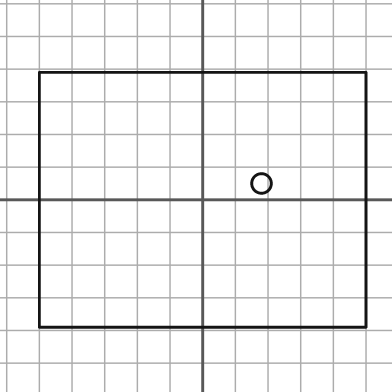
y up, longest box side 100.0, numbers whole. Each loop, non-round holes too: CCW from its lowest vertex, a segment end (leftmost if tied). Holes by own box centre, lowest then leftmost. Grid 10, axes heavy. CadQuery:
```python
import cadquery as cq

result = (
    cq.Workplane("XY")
    .moveTo(-50.0, -39.0)
    .lineTo(50.0, -39.0)
    .lineTo(50.0, 39.0)
    .lineTo(-50.0, 39.0)
    .close()
    .moveTo(18.0, 5.0)
    .circle(3.0)
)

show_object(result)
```